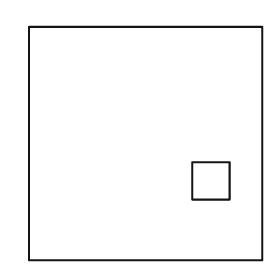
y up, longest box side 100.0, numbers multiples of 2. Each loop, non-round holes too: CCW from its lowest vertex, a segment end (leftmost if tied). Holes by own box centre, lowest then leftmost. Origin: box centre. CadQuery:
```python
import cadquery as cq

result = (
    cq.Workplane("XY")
    .moveTo(-50.0, -50.0)
    .lineTo(50.0, -50.0)
    .lineTo(50.0, 50.0)
    .lineTo(-50.0, 50.0)
    .close()
    .moveTo(20.0, -24.0)
    .lineTo(36.0, -24.0)
    .lineTo(36.0, -8.0)
    .lineTo(20.0, -8.0)
    .close()
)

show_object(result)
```